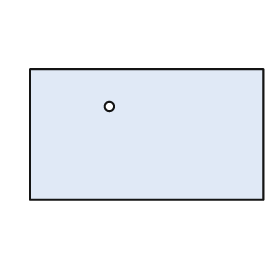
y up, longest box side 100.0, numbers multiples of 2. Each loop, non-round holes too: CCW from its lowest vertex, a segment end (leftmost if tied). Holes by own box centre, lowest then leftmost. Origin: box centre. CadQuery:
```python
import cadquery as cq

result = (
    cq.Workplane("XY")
    .moveTo(-50.0, -28.0)
    .lineTo(50.0, -28.0)
    .lineTo(50.0, 28.0)
    .lineTo(-50.0, 28.0)
    .close()
    .moveTo(-16.0, 12.0)
    .circle(2.0)
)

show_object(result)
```